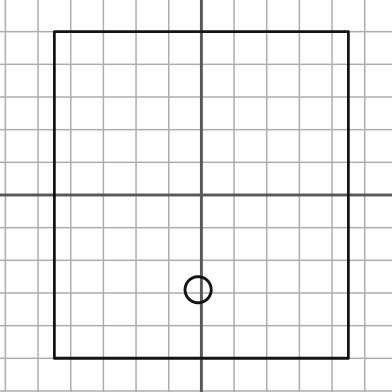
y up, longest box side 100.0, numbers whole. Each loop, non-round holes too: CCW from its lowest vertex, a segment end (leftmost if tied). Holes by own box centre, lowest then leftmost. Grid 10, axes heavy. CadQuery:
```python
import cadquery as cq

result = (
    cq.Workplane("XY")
    .moveTo(-45.0, -50.0)
    .lineTo(45.0, -50.0)
    .lineTo(45.0, 50.0)
    .lineTo(-45.0, 50.0)
    .close()
    .moveTo(-1.0, -29.0)
    .circle(4.0)
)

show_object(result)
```